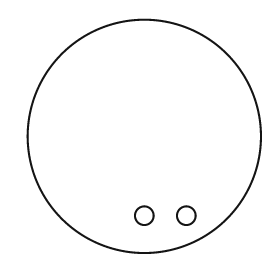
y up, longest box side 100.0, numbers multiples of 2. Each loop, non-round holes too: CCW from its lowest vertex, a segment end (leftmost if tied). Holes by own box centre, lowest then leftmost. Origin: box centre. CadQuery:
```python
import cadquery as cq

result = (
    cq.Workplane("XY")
    .moveTo(0.0, 0.0)
    .circle(50.0)
    .moveTo(0.0, -34.0)
    .circle(4.0)
    .moveTo(18.0, -34.0)
    .circle(4.0)
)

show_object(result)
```